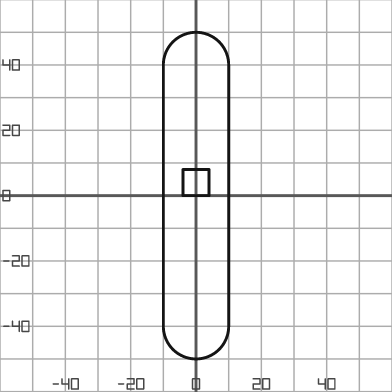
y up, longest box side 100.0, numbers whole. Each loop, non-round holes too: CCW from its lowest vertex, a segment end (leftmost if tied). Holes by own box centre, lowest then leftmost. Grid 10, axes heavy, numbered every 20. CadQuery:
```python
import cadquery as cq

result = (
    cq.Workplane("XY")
    .moveTo(-10.0, -40.0)
    .threePointArc((0.0, -50.0), (10.0, -40.0))
    .lineTo(10.0, 40.0)
    .threePointArc((0.0, 50.0), (-10.0, 40.0))
    .close()
    .moveTo(-4.0, 0.0)
    .lineTo(4.0, 0.0)
    .lineTo(4.0, 8.0)
    .lineTo(-4.0, 8.0)
    .close()
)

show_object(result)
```